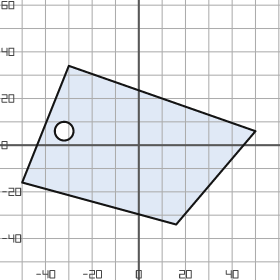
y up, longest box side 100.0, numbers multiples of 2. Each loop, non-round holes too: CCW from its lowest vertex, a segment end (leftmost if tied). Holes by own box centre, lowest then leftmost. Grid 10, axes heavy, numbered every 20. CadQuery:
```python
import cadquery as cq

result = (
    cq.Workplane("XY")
    .moveTo(16.0, -34.0)
    .lineTo(50.0, 6.0)
    .lineTo(-30.0, 34.0)
    .lineTo(-50.0, -16.0)
    .close()
    .moveTo(-32.0, 6.0)
    .circle(4.0)
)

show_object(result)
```